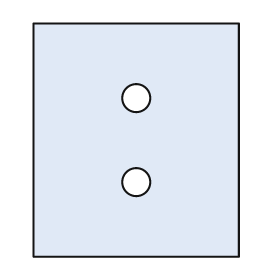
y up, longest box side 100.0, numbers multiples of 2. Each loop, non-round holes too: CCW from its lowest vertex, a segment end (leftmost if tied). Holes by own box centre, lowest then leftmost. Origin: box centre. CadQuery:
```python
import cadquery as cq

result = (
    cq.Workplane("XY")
    .moveTo(-44.0, -50.0)
    .lineTo(44.0, -50.0)
    .lineTo(44.0, 50.0)
    .lineTo(-44.0, 50.0)
    .close()
    .moveTo(0.0, -18.0)
    .circle(6.0)
    .moveTo(0.0, 18.0)
    .circle(6.0)
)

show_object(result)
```